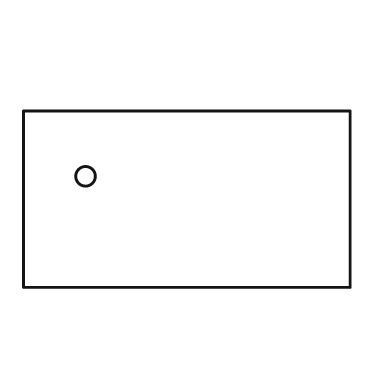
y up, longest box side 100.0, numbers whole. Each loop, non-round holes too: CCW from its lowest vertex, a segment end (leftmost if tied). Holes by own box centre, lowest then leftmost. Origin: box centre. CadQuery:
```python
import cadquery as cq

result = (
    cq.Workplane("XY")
    .moveTo(-50.0, -27.0)
    .lineTo(50.0, -27.0)
    .lineTo(50.0, 27.0)
    .lineTo(-50.0, 27.0)
    .close()
    .moveTo(-31.0, 7.0)
    .circle(3.0)
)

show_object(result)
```